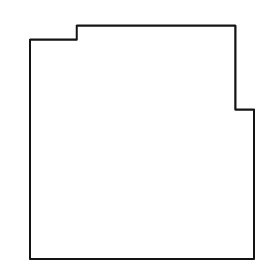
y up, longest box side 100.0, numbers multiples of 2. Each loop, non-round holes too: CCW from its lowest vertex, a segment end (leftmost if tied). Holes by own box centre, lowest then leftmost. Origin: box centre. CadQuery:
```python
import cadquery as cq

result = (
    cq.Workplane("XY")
    .moveTo(-48.0, -50.0)
    .lineTo(48.0, -50.0)
    .lineTo(48.0, 14.0)
    .lineTo(40.0, 14.0)
    .lineTo(40.0, 50.0)
    .lineTo(-28.0, 50.0)
    .lineTo(-28.0, 44.0)
    .lineTo(-48.0, 44.0)
    .close()
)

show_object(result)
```